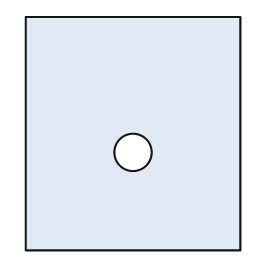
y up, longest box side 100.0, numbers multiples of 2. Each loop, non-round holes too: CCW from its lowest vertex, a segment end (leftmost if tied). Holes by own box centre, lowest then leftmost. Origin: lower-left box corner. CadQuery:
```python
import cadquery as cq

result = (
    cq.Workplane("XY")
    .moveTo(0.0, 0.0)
    .lineTo(92.0, 0.0)
    .lineTo(92.0, 100.0)
    .lineTo(0.0, 100.0)
    .close()
    .moveTo(46.0, 42.0)
    .circle(8.0)
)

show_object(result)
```